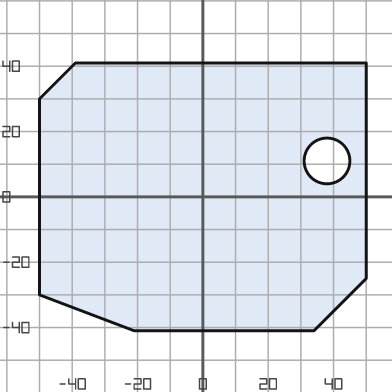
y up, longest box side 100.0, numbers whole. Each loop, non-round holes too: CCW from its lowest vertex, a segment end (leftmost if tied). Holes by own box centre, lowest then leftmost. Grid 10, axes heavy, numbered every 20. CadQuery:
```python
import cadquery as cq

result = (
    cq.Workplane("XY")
    .moveTo(-21.0, -41.0)
    .lineTo(34.0, -41.0)
    .lineTo(50.0, -25.0)
    .lineTo(50.0, 41.0)
    .lineTo(-39.0, 41.0)
    .lineTo(-50.0, 30.0)
    .lineTo(-50.0, -30.0)
    .close()
    .moveTo(38.0, 11.0)
    .circle(7.0)
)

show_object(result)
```